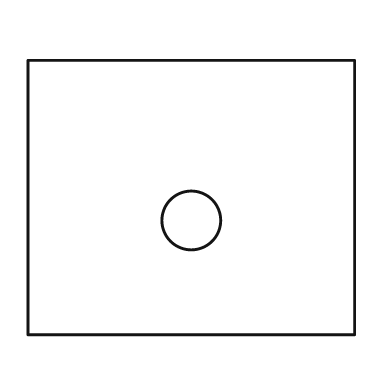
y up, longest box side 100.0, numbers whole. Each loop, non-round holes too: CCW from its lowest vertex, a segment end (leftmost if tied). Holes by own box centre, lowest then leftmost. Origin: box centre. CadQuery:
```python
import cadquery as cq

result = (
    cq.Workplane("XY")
    .moveTo(-50.0, -42.0)
    .lineTo(50.0, -42.0)
    .lineTo(50.0, 42.0)
    .lineTo(-50.0, 42.0)
    .close()
    .moveTo(0.0, -7.0)
    .circle(9.0)
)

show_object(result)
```